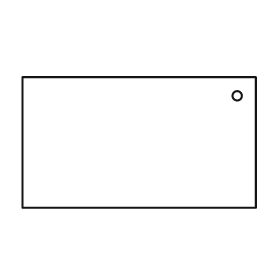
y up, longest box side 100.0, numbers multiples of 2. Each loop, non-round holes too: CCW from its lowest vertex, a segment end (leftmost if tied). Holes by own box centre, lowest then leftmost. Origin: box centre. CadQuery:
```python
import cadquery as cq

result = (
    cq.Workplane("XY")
    .moveTo(-50.0, -28.0)
    .lineTo(50.0, -28.0)
    .lineTo(50.0, 28.0)
    .lineTo(-50.0, 28.0)
    .close()
    .moveTo(42.0, 20.0)
    .circle(2.0)
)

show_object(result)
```